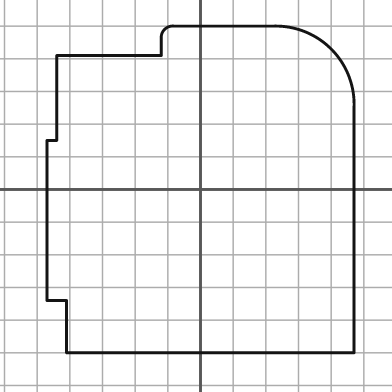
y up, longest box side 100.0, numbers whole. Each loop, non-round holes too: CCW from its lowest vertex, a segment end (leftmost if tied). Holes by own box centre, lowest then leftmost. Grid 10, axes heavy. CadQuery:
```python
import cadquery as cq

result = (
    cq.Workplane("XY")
    .moveTo(-41.0, -50.0)
    .lineTo(47.0, -50.0)
    .lineTo(47.0, 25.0)
    .threePointArc((40.0, 43.0), (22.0, 50.0))
    .lineTo(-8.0, 50.0)
    .threePointArc((-11.0, 49.0), (-12.0, 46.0))
    .lineTo(-12.0, 41.0)
    .lineTo(-44.0, 41.0)
    .lineTo(-44.0, 15.0)
    .lineTo(-47.0, 15.0)
    .lineTo(-47.0, -34.0)
    .lineTo(-41.0, -34.0)
    .close()
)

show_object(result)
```